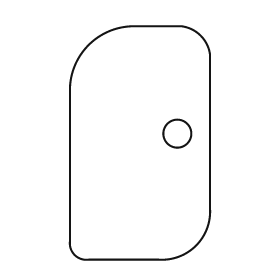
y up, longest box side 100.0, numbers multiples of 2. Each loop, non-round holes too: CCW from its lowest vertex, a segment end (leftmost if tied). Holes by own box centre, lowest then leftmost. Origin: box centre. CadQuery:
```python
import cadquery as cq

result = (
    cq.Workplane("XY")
    .moveTo(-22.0, -50.0)
    .lineTo(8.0, -50.0)
    .threePointArc((24.0, -44.0), (30.0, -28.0))
    .lineTo(30.0, 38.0)
    .threePointArc((26.0, 46.0), (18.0, 50.0))
    .lineTo(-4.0, 50.0)
    .threePointArc((-22.0, 42.0), (-30.0, 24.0))
    .lineTo(-30.0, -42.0)
    .threePointArc((-28.0, -48.0), (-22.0, -50.0))
    .close()
    .moveTo(16.0, 4.0)
    .circle(6.0)
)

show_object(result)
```